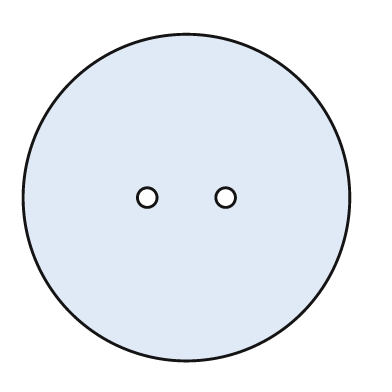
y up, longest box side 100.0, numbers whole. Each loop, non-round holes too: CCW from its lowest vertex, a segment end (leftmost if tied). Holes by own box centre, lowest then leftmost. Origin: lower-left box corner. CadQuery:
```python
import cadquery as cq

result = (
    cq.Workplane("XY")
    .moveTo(50.0, 50.0)
    .circle(50.0)
    .moveTo(38.0, 50.0)
    .circle(3.0)
    .moveTo(62.0, 50.0)
    .circle(3.0)
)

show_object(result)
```